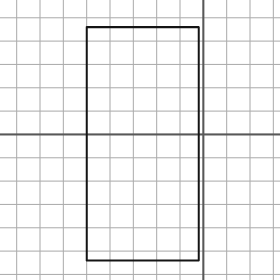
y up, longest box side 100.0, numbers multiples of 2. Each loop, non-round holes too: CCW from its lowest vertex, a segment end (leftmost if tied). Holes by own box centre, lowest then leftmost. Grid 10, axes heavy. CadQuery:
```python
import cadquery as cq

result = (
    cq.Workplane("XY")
    .moveTo(-50.0, -54.0)
    .lineTo(-2.0, -54.0)
    .lineTo(-2.0, 46.0)
    .lineTo(-50.0, 46.0)
    .close()
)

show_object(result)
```